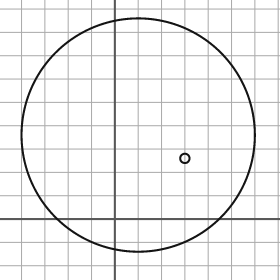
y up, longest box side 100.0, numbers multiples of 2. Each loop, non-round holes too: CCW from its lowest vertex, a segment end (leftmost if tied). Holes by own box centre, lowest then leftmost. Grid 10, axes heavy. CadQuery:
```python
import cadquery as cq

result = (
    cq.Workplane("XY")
    .moveTo(10.0, 36.0)
    .circle(50.0)
    .moveTo(30.0, 26.0)
    .circle(2.0)
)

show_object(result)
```